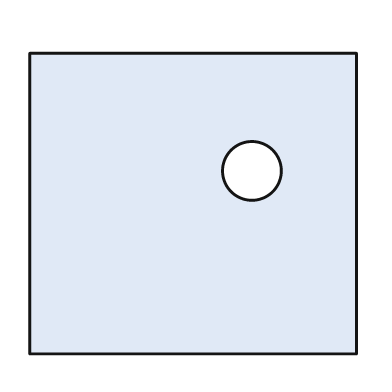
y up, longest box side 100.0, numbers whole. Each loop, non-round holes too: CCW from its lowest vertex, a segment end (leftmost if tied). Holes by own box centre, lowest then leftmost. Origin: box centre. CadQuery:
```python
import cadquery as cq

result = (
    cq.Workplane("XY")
    .moveTo(-50.0, -46.0)
    .lineTo(50.0, -46.0)
    .lineTo(50.0, 46.0)
    .lineTo(-50.0, 46.0)
    .close()
    .moveTo(18.0, 10.0)
    .circle(9.0)
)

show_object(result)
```